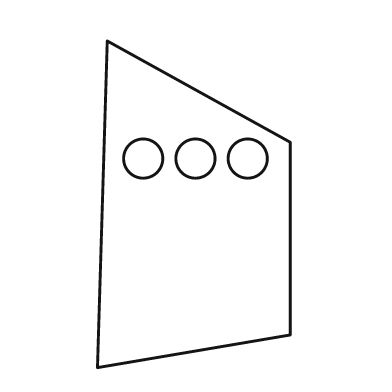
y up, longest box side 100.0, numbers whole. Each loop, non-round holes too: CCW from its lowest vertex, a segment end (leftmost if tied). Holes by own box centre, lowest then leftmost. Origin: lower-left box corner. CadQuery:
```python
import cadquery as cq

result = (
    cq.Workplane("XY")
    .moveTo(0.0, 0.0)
    .lineTo(59.0, 10.0)
    .lineTo(59.0, 69.0)
    .lineTo(3.0, 100.0)
    .close()
    .moveTo(14.0, 64.0)
    .circle(6.0)
    .moveTo(30.0, 64.0)
    .circle(6.0)
    .moveTo(46.0, 64.0)
    .circle(6.0)
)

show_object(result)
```